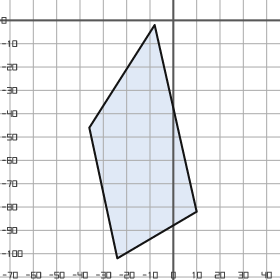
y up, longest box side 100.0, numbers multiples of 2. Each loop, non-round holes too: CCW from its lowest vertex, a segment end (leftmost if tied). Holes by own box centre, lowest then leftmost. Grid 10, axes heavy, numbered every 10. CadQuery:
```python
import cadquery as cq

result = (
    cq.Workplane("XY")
    .moveTo(-24.0, -102.0)
    .lineTo(10.0, -82.0)
    .lineTo(-8.0, -2.0)
    .lineTo(-36.0, -46.0)
    .close()
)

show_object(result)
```